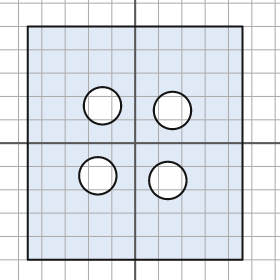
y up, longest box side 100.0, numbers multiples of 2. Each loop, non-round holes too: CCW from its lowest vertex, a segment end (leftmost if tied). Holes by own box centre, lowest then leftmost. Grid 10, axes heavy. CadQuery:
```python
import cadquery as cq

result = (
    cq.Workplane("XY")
    .moveTo(-46.0, -50.0)
    .lineTo(46.0, -50.0)
    .lineTo(46.0, 50.0)
    .lineTo(-46.0, 50.0)
    .close()
    .moveTo(14.0, -16.0)
    .circle(8.0)
    .moveTo(-16.0, -14.0)
    .circle(8.0)
    .moveTo(16.0, 14.0)
    .circle(8.0)
    .moveTo(-14.0, 16.0)
    .circle(8.0)
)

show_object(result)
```